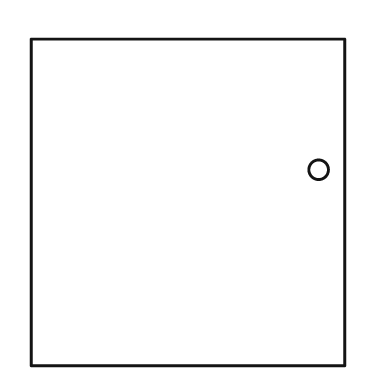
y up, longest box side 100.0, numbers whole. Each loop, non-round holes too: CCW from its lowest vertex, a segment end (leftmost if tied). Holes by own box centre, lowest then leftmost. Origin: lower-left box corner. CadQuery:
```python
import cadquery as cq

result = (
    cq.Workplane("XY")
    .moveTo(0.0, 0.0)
    .lineTo(96.0, 0.0)
    .lineTo(96.0, 100.0)
    .lineTo(0.0, 100.0)
    .close()
    .moveTo(88.0, 60.0)
    .circle(3.0)
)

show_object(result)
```